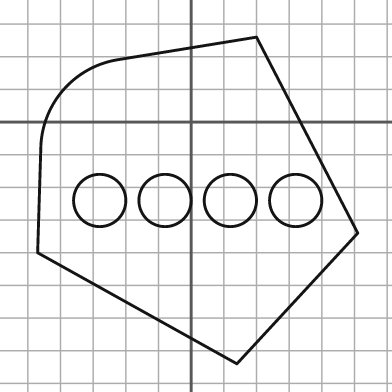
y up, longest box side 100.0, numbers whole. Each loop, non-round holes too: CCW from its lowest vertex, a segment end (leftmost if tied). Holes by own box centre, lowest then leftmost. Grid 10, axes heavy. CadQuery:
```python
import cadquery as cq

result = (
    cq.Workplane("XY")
    .moveTo(14.0, -74.0)
    .lineTo(51.0, -34.0)
    .lineTo(20.0, 26.0)
    .lineTo(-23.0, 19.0)
    .threePointArc((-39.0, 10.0), (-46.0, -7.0))
    .lineTo(-47.0, -40.0)
    .close()
    .moveTo(-28.0, -24.0)
    .circle(8.0)
    .moveTo(-8.0, -24.0)
    .circle(8.0)
    .moveTo(12.0, -24.0)
    .circle(8.0)
    .moveTo(32.0, -24.0)
    .circle(8.0)
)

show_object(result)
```